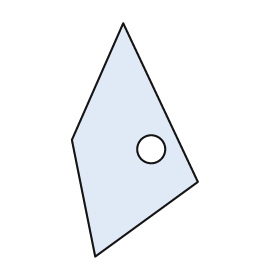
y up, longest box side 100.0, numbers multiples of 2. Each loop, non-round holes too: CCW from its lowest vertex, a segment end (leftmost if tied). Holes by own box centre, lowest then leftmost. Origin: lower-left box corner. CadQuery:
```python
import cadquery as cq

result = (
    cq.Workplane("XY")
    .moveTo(10.0, 0.0)
    .lineTo(54.0, 32.0)
    .lineTo(22.0, 100.0)
    .lineTo(0.0, 50.0)
    .close()
    .moveTo(34.0, 46.0)
    .circle(6.0)
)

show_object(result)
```